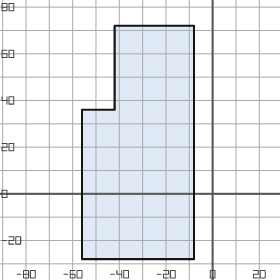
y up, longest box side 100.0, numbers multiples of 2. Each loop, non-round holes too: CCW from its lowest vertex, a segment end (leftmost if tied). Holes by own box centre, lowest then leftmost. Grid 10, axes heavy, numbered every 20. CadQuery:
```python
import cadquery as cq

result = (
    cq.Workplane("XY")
    .moveTo(-56.0, -28.0)
    .lineTo(-8.0, -28.0)
    .lineTo(-8.0, 72.0)
    .lineTo(-42.0, 72.0)
    .lineTo(-42.0, 36.0)
    .lineTo(-56.0, 36.0)
    .close()
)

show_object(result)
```